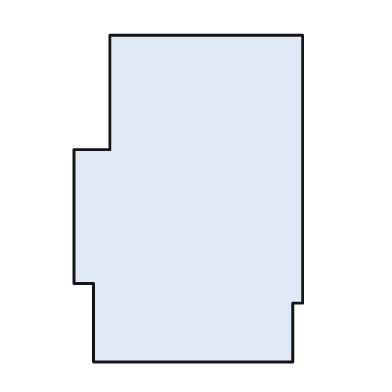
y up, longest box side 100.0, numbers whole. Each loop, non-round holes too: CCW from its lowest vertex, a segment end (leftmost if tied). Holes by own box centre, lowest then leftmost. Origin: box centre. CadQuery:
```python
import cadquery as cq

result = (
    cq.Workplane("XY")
    .moveTo(-29.0, -50.0)
    .lineTo(32.0, -50.0)
    .lineTo(32.0, -32.0)
    .lineTo(35.0, -32.0)
    .lineTo(35.0, 50.0)
    .lineTo(-24.0, 50.0)
    .lineTo(-24.0, 15.0)
    .lineTo(-35.0, 15.0)
    .lineTo(-35.0, -26.0)
    .lineTo(-29.0, -26.0)
    .close()
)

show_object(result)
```